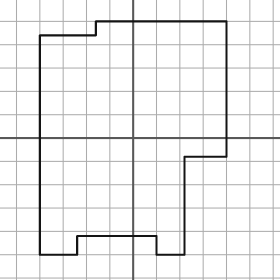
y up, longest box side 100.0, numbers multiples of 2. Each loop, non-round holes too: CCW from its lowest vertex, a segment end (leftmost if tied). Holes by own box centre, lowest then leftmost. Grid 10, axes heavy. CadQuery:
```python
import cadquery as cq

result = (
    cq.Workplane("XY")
    .moveTo(-40.0, -50.0)
    .lineTo(-24.0, -50.0)
    .lineTo(-24.0, -42.0)
    .lineTo(10.0, -42.0)
    .lineTo(10.0, -50.0)
    .lineTo(22.0, -50.0)
    .lineTo(22.0, -8.0)
    .lineTo(40.0, -8.0)
    .lineTo(40.0, 50.0)
    .lineTo(-16.0, 50.0)
    .lineTo(-16.0, 44.0)
    .lineTo(-40.0, 44.0)
    .close()
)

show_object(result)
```